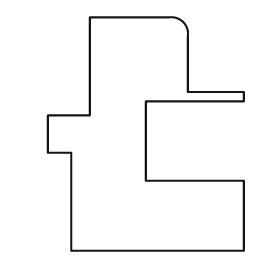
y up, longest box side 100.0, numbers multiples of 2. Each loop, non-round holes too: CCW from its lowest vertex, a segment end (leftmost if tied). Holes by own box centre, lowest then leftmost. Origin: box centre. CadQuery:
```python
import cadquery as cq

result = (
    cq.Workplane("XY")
    .moveTo(-32.0, -50.0)
    .lineTo(42.0, -50.0)
    .lineTo(42.0, -20.0)
    .lineTo(0.0, -20.0)
    .lineTo(0.0, 14.0)
    .lineTo(42.0, 14.0)
    .lineTo(42.0, 18.0)
    .lineTo(18.0, 18.0)
    .lineTo(18.0, 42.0)
    .threePointArc((16.0, 48.0), (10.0, 50.0))
    .lineTo(-24.0, 50.0)
    .lineTo(-24.0, 8.0)
    .lineTo(-42.0, 8.0)
    .lineTo(-42.0, -8.0)
    .lineTo(-32.0, -8.0)
    .close()
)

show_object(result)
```